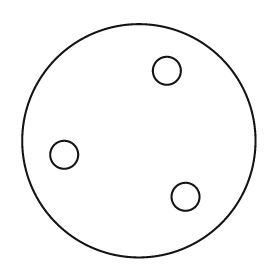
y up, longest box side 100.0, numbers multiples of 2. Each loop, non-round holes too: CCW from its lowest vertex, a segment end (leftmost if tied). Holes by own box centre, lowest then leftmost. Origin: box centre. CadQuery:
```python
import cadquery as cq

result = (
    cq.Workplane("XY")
    .moveTo(0.0, 0.0)
    .circle(50.0)
    .moveTo(20.0, -24.0)
    .circle(6.0)
    .moveTo(-32.0, -6.0)
    .circle(6.0)
    .moveTo(12.0, 30.0)
    .circle(6.0)
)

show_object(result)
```